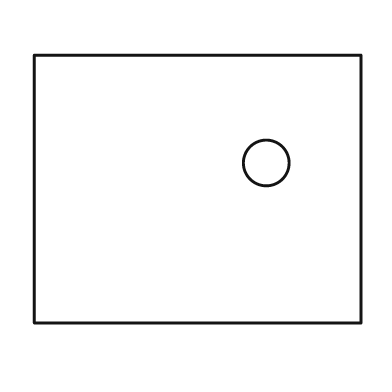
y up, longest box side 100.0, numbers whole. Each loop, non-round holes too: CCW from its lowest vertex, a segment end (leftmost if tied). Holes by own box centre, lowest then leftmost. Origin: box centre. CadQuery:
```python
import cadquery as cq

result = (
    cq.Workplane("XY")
    .moveTo(-50.0, -41.0)
    .lineTo(50.0, -41.0)
    .lineTo(50.0, 41.0)
    .lineTo(-50.0, 41.0)
    .close()
    .moveTo(21.0, 8.0)
    .circle(7.0)
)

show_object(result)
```